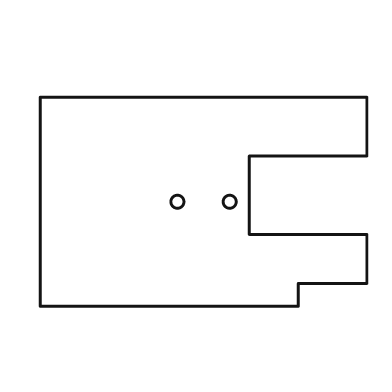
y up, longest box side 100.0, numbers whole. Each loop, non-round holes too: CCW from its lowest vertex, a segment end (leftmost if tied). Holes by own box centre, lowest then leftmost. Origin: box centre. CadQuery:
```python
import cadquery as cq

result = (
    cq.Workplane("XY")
    .moveTo(-50.0, -32.0)
    .lineTo(29.0, -32.0)
    .lineTo(29.0, -25.0)
    .lineTo(50.0, -25.0)
    .lineTo(50.0, -10.0)
    .lineTo(14.0, -10.0)
    .lineTo(14.0, 14.0)
    .lineTo(50.0, 14.0)
    .lineTo(50.0, 32.0)
    .lineTo(-50.0, 32.0)
    .close()
    .moveTo(-8.0, 0.0)
    .circle(2.0)
    .moveTo(8.0, 0.0)
    .circle(2.0)
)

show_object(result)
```